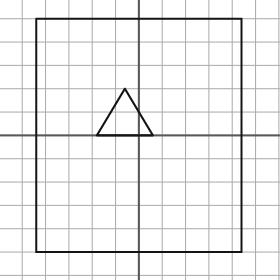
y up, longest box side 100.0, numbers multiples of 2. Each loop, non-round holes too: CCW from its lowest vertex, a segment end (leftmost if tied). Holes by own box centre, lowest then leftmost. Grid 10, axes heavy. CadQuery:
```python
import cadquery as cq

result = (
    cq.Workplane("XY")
    .moveTo(-44.0, -50.0)
    .lineTo(44.0, -50.0)
    .lineTo(44.0, 50.0)
    .lineTo(-44.0, 50.0)
    .close()
    .moveTo(-18.0, 0.0)
    .lineTo(6.0, 0.0)
    .lineTo(-6.0, 20.0)
    .close()
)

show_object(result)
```